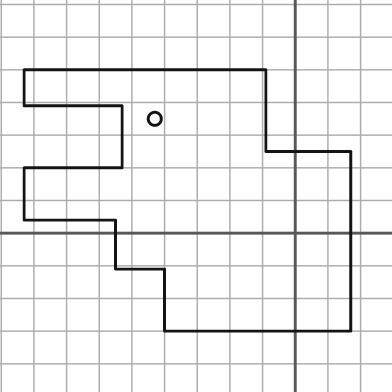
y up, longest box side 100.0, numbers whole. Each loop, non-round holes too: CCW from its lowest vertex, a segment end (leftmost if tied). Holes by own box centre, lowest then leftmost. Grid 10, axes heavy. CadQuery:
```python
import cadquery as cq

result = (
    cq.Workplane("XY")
    .moveTo(-40.0, -30.0)
    .lineTo(17.0, -30.0)
    .lineTo(17.0, 25.0)
    .lineTo(-9.0, 25.0)
    .lineTo(-9.0, 50.0)
    .lineTo(-83.0, 50.0)
    .lineTo(-83.0, 39.0)
    .lineTo(-53.0, 39.0)
    .lineTo(-53.0, 20.0)
    .lineTo(-83.0, 20.0)
    .lineTo(-83.0, 4.0)
    .lineTo(-55.0, 4.0)
    .lineTo(-55.0, -11.0)
    .lineTo(-40.0, -11.0)
    .close()
    .moveTo(-43.0, 35.0)
    .circle(2.0)
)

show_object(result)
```